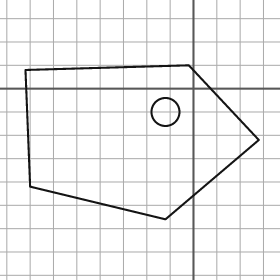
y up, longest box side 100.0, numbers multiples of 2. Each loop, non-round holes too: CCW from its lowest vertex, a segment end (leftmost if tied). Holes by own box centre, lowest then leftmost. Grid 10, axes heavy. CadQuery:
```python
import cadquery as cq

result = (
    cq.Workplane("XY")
    .moveTo(-12.0, -56.0)
    .lineTo(28.0, -22.0)
    .lineTo(-2.0, 10.0)
    .lineTo(-72.0, 8.0)
    .lineTo(-70.0, -42.0)
    .close()
    .moveTo(-12.0, -10.0)
    .circle(6.0)
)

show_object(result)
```